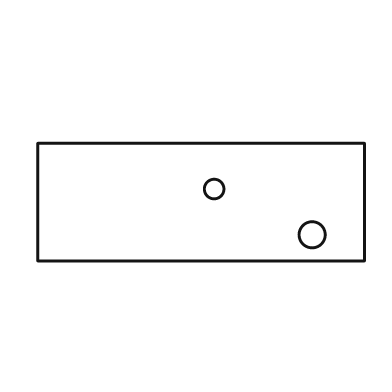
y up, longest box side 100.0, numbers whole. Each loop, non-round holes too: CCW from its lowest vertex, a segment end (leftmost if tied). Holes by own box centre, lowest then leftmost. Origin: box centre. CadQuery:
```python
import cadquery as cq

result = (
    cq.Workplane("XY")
    .moveTo(-50.0, -18.0)
    .lineTo(50.0, -18.0)
    .lineTo(50.0, 18.0)
    .lineTo(-50.0, 18.0)
    .close()
    .moveTo(34.0, -10.0)
    .circle(4.0)
    .moveTo(4.0, 4.0)
    .circle(3.0)
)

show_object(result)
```